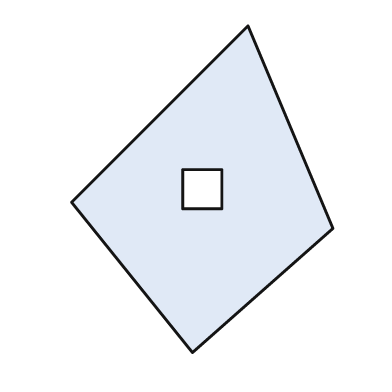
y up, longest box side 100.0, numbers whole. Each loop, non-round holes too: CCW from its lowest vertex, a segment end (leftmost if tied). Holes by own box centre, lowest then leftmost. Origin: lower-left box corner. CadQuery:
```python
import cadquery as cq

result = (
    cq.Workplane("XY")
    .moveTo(37.0, 0.0)
    .lineTo(80.0, 38.0)
    .lineTo(54.0, 100.0)
    .lineTo(0.0, 46.0)
    .close()
    .moveTo(34.0, 44.0)
    .lineTo(46.0, 44.0)
    .lineTo(46.0, 56.0)
    .lineTo(34.0, 56.0)
    .close()
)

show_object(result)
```